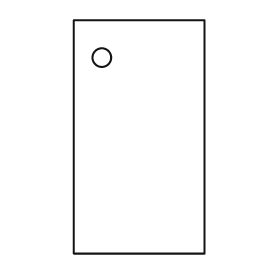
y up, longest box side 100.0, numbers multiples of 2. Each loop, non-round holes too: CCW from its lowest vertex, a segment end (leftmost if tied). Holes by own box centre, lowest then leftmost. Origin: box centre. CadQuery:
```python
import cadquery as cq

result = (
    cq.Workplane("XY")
    .moveTo(-28.0, -50.0)
    .lineTo(28.0, -50.0)
    .lineTo(28.0, 50.0)
    .lineTo(-28.0, 50.0)
    .close()
    .moveTo(-16.0, 34.0)
    .circle(4.0)
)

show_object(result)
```